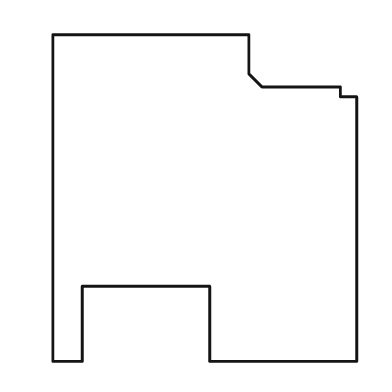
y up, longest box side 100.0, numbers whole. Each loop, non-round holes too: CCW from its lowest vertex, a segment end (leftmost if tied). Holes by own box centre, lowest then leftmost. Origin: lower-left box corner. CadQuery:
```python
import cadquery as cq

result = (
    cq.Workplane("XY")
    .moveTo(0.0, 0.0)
    .lineTo(9.0, 0.0)
    .lineTo(9.0, 23.0)
    .lineTo(48.0, 23.0)
    .lineTo(48.0, 0.0)
    .lineTo(93.0, 0.0)
    .lineTo(93.0, 81.0)
    .lineTo(88.0, 81.0)
    .lineTo(88.0, 84.0)
    .lineTo(64.0, 84.0)
    .lineTo(60.0, 88.0)
    .lineTo(60.0, 100.0)
    .lineTo(0.0, 100.0)
    .close()
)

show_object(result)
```